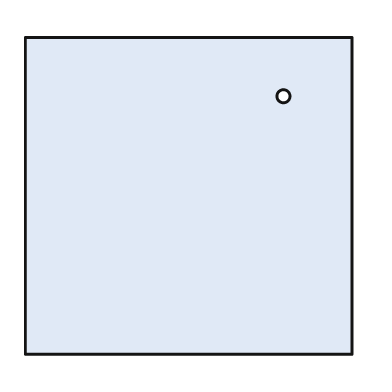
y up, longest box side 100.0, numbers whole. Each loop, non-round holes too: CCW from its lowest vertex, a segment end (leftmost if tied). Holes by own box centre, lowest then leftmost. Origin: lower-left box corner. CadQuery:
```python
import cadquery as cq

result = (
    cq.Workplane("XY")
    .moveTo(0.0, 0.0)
    .lineTo(100.0, 0.0)
    .lineTo(100.0, 97.0)
    .lineTo(0.0, 97.0)
    .close()
    .moveTo(79.0, 79.0)
    .circle(2.0)
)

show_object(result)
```